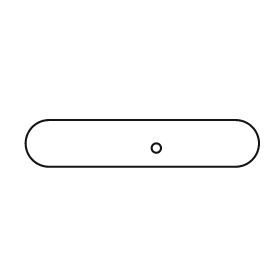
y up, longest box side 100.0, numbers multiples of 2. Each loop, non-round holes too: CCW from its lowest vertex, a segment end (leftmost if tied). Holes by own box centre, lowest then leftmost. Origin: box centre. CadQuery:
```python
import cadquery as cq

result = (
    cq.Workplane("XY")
    .moveTo(-40.0, -10.0)
    .lineTo(40.0, -10.0)
    .threePointArc((50.0, 0.0), (40.0, 10.0))
    .lineTo(-40.0, 10.0)
    .threePointArc((-50.0, 0.0), (-40.0, -10.0))
    .close()
    .moveTo(6.0, -2.0)
    .circle(2.0)
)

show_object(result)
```